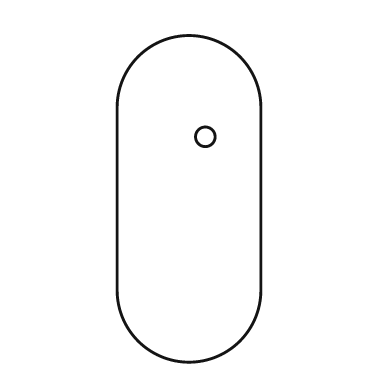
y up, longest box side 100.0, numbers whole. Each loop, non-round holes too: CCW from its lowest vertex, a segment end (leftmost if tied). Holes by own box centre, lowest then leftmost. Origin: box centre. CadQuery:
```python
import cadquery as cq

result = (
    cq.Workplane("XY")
    .moveTo(-22.0, -28.0)
    .threePointArc((0.0, -50.0), (22.0, -28.0))
    .lineTo(22.0, 28.0)
    .threePointArc((0.0, 50.0), (-22.0, 28.0))
    .close()
    .moveTo(5.0, 19.0)
    .circle(3.0)
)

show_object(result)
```